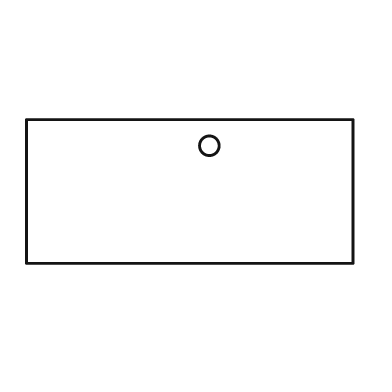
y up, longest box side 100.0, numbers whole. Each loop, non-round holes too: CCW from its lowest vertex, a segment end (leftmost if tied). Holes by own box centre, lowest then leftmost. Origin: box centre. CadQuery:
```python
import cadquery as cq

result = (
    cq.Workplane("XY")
    .moveTo(-50.0, -22.0)
    .lineTo(50.0, -22.0)
    .lineTo(50.0, 22.0)
    .lineTo(-50.0, 22.0)
    .close()
    .moveTo(6.0, 14.0)
    .circle(3.0)
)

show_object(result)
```